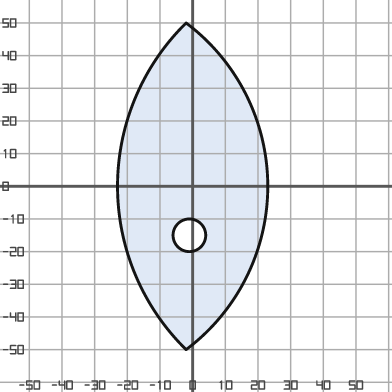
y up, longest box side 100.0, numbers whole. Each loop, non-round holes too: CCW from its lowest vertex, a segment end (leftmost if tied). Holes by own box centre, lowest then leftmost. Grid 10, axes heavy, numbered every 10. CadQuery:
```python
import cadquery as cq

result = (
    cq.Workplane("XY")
    .moveTo(-2.0, -50.0)
    .threePointArc((23.0, 0.0), (-2.0, 50.0))
    .threePointArc((-23.0, 0.0), (-2.0, -50.0))
    .close()
    .moveTo(-1.0, -15.0)
    .circle(5.0)
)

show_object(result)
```